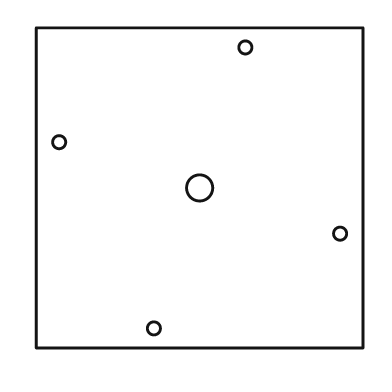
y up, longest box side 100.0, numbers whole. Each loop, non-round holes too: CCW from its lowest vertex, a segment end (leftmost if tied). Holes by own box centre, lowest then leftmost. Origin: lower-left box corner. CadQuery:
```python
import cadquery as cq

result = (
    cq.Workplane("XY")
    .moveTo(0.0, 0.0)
    .lineTo(100.0, 0.0)
    .lineTo(100.0, 98.0)
    .lineTo(0.0, 98.0)
    .close()
    .moveTo(36.0, 6.0)
    .circle(2.0)
    .moveTo(93.0, 35.0)
    .circle(2.0)
    .moveTo(50.0, 49.0)
    .circle(4.0)
    .moveTo(7.0, 63.0)
    .circle(2.0)
    .moveTo(64.0, 92.0)
    .circle(2.0)
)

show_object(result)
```